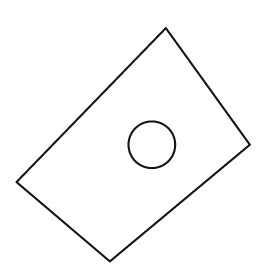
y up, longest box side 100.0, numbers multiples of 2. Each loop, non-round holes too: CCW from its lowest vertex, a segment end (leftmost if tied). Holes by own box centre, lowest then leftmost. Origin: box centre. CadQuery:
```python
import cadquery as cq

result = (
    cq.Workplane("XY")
    .moveTo(-10.0, -50.0)
    .lineTo(50.0, 0.0)
    .lineTo(14.0, 50.0)
    .lineTo(-50.0, -16.0)
    .close()
    .moveTo(8.0, 0.0)
    .circle(10.0)
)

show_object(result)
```